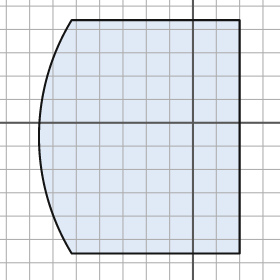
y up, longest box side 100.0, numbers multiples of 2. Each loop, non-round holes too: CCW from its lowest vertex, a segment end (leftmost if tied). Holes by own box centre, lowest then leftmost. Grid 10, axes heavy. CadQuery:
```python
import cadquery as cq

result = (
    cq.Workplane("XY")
    .moveTo(-52.0, -56.0)
    .lineTo(20.0, -56.0)
    .lineTo(20.0, 44.0)
    .lineTo(-52.0, 44.0)
    .threePointArc((-66.0, -6.0), (-52.0, -56.0))
    .close()
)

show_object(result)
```